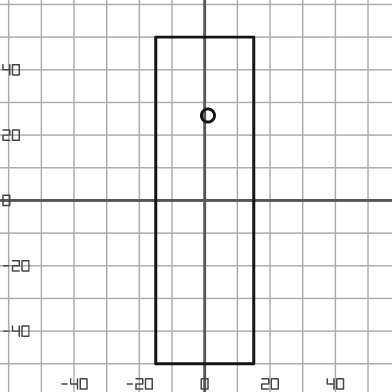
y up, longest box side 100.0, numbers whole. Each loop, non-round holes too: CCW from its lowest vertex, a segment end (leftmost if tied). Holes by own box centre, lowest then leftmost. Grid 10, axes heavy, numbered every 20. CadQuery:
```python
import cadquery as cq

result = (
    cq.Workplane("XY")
    .moveTo(-15.0, -50.0)
    .lineTo(15.0, -50.0)
    .lineTo(15.0, 50.0)
    .lineTo(-15.0, 50.0)
    .close()
    .moveTo(1.0, 26.0)
    .circle(2.0)
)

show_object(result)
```